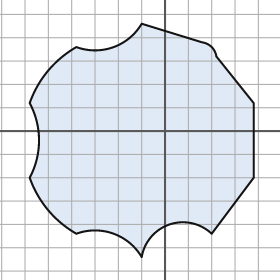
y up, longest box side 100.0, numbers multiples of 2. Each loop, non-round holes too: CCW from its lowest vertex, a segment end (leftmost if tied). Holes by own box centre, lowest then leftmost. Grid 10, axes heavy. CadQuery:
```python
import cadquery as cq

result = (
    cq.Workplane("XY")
    .moveTo(-10.0, -54.0)
    .threePointArc((2.0, -40.0), (20.0, -44.0))
    .lineTo(38.0, -20.0)
    .lineTo(38.0, 12.0)
    .lineTo(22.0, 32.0)
    .threePointArc((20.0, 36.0), (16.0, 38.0))
    .lineTo(-10.0, 46.0)
    .threePointArc((-22.0, 36.0), (-38.0, 36.0))
    .threePointArc((-50.0, 26.0), (-58.0, 12.0))
    .threePointArc((-54.0, -4.0), (-58.0, -20.0))
    .threePointArc((-50.0, -34.0), (-38.0, -44.0))
    .threePointArc((-22.0, -44.0), (-10.0, -54.0))
    .close()
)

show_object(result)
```